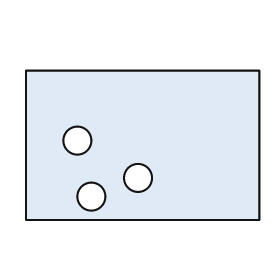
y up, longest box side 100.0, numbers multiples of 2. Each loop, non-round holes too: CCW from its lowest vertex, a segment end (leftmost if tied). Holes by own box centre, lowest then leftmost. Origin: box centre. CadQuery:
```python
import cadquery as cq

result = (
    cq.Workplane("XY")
    .moveTo(-50.0, -32.0)
    .lineTo(50.0, -32.0)
    .lineTo(50.0, 32.0)
    .lineTo(-50.0, 32.0)
    .close()
    .moveTo(-22.0, -22.0)
    .circle(6.0)
    .moveTo(-2.0, -14.0)
    .circle(6.0)
    .moveTo(-28.0, 2.0)
    .circle(6.0)
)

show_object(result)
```